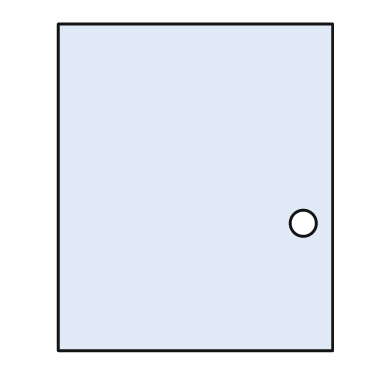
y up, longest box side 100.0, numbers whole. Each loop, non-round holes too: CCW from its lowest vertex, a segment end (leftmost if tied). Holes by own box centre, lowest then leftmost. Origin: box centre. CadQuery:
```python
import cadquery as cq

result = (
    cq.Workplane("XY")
    .moveTo(-42.0, -50.0)
    .lineTo(42.0, -50.0)
    .lineTo(42.0, 50.0)
    .lineTo(-42.0, 50.0)
    .close()
    .moveTo(33.0, -11.0)
    .circle(4.0)
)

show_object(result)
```